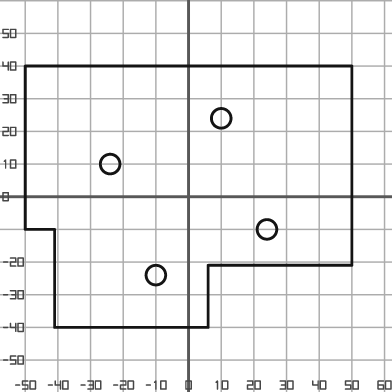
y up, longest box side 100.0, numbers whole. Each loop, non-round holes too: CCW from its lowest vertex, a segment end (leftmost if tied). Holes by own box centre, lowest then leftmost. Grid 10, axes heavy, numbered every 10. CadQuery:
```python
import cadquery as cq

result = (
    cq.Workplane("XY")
    .moveTo(-41.0, -40.0)
    .lineTo(6.0, -40.0)
    .lineTo(6.0, -21.0)
    .lineTo(50.0, -21.0)
    .lineTo(50.0, 40.0)
    .lineTo(-50.0, 40.0)
    .lineTo(-50.0, -10.0)
    .lineTo(-41.0, -10.0)
    .close()
    .moveTo(-10.0, -24.0)
    .circle(3.0)
    .moveTo(24.0, -10.0)
    .circle(3.0)
    .moveTo(-24.0, 10.0)
    .circle(3.0)
    .moveTo(10.0, 24.0)
    .circle(3.0)
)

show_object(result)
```